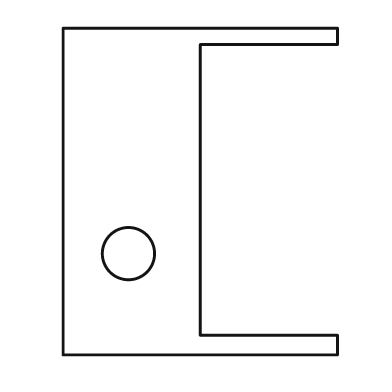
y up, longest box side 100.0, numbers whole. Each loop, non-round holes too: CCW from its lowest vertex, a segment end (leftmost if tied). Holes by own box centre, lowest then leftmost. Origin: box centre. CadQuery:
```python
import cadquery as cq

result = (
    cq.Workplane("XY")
    .moveTo(-42.0, -50.0)
    .lineTo(42.0, -50.0)
    .lineTo(42.0, -44.0)
    .lineTo(0.0, -44.0)
    .lineTo(0.0, 45.0)
    .lineTo(42.0, 45.0)
    .lineTo(42.0, 50.0)
    .lineTo(-42.0, 50.0)
    .close()
    .moveTo(-22.0, -19.0)
    .circle(8.0)
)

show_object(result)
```